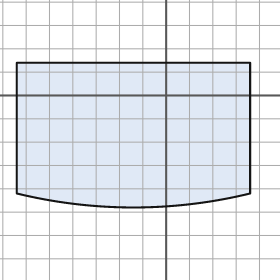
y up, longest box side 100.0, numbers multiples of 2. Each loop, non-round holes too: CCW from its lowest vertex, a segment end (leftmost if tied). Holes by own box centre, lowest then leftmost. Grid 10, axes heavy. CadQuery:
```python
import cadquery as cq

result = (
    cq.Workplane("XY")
    .moveTo(-64.0, -42.0)
    .threePointArc((-14.0, -48.0), (36.0, -42.0))
    .lineTo(36.0, 14.0)
    .lineTo(-64.0, 14.0)
    .close()
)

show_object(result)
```